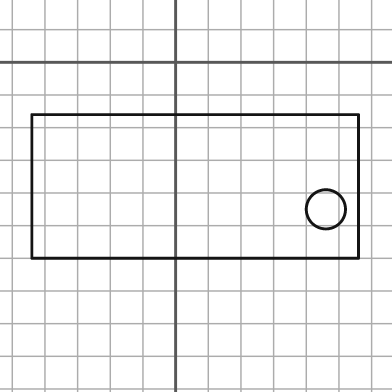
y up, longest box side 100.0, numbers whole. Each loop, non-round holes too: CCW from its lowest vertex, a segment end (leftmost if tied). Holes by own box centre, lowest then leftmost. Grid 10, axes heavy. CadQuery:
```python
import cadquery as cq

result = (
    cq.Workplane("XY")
    .moveTo(-44.0, -60.0)
    .lineTo(56.0, -60.0)
    .lineTo(56.0, -16.0)
    .lineTo(-44.0, -16.0)
    .close()
    .moveTo(46.0, -45.0)
    .circle(6.0)
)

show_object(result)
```